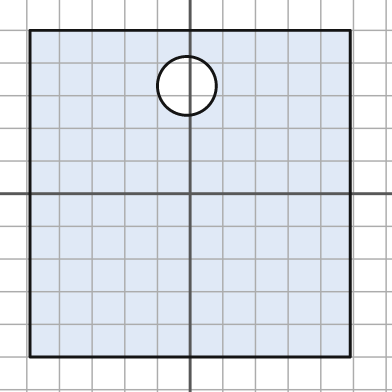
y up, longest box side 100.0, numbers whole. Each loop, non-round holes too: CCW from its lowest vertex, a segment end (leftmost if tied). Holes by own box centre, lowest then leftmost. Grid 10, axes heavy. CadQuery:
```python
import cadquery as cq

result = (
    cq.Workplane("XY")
    .moveTo(-49.0, -50.0)
    .lineTo(49.0, -50.0)
    .lineTo(49.0, 50.0)
    .lineTo(-49.0, 50.0)
    .close()
    .moveTo(-1.0, 33.0)
    .circle(9.0)
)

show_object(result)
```